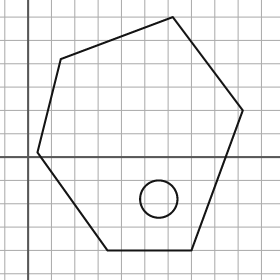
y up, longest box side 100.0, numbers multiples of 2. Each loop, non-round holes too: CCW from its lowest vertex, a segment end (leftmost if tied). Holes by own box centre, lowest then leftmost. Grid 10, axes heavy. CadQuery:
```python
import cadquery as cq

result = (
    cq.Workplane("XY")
    .moveTo(34.0, -40.0)
    .lineTo(70.0, -40.0)
    .lineTo(92.0, 20.0)
    .lineTo(62.0, 60.0)
    .lineTo(14.0, 42.0)
    .lineTo(4.0, 2.0)
    .close()
    .moveTo(56.0, -18.0)
    .circle(8.0)
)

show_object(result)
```